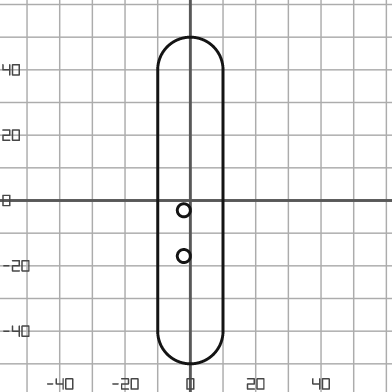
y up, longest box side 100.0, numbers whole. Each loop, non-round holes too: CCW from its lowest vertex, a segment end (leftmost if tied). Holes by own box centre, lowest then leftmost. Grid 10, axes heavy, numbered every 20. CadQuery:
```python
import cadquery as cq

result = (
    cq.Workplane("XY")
    .moveTo(-10.0, -40.0)
    .threePointArc((0.0, -50.0), (10.0, -40.0))
    .lineTo(10.0, 40.0)
    .threePointArc((0.0, 50.0), (-10.0, 40.0))
    .close()
    .moveTo(-2.0, -17.0)
    .circle(2.0)
    .moveTo(-2.0, -3.0)
    .circle(2.0)
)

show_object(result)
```